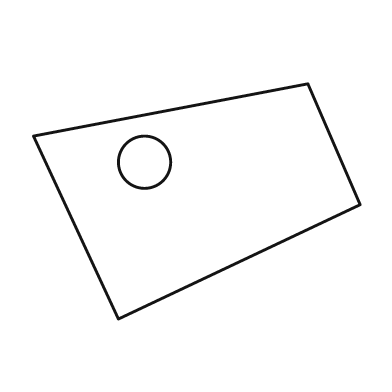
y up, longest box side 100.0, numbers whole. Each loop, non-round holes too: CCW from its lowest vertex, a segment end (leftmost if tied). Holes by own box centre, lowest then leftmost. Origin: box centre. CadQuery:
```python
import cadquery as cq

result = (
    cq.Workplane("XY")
    .moveTo(-24.0, -36.0)
    .lineTo(50.0, -1.0)
    .lineTo(34.0, 36.0)
    .lineTo(-50.0, 20.0)
    .close()
    .moveTo(-16.0, 12.0)
    .circle(8.0)
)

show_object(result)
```